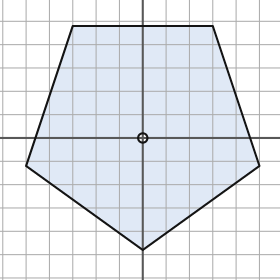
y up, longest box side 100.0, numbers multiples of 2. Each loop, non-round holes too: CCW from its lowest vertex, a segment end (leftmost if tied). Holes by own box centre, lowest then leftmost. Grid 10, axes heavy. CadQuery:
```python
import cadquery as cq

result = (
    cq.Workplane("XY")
    .moveTo(0.0, -48.0)
    .lineTo(50.0, -12.0)
    .lineTo(30.0, 48.0)
    .lineTo(-30.0, 48.0)
    .lineTo(-50.0, -12.0)
    .close()
    .moveTo(0.0, 0.0)
    .circle(2.0)
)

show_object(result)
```